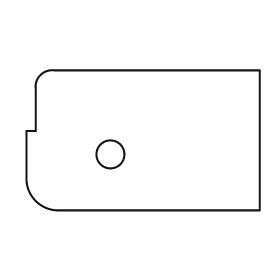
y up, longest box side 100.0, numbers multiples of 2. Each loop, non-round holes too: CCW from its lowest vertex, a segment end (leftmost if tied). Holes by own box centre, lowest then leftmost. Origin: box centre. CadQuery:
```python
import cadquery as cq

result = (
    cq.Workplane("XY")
    .moveTo(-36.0, -30.0)
    .lineTo(50.0, -30.0)
    .lineTo(50.0, 30.0)
    .lineTo(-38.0, 30.0)
    .threePointArc((-44.0, 28.0), (-46.0, 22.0))
    .lineTo(-46.0, 4.0)
    .lineTo(-50.0, 4.0)
    .lineTo(-50.0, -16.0)
    .threePointArc((-46.0, -26.0), (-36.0, -30.0))
    .close()
    .moveTo(-14.0, -6.0)
    .circle(6.0)
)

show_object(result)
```